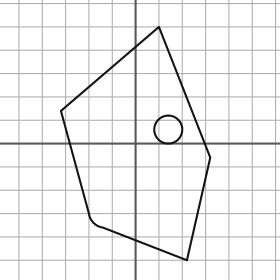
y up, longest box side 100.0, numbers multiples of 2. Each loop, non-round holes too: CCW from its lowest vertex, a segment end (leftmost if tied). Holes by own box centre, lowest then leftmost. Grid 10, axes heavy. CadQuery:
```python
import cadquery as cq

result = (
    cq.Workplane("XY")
    .moveTo(22.0, -50.0)
    .lineTo(32.0, -6.0)
    .lineTo(10.0, 50.0)
    .lineTo(-32.0, 14.0)
    .lineTo(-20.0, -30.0)
    .threePointArc((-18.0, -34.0), (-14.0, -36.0))
    .close()
    .moveTo(14.0, 6.0)
    .circle(6.0)
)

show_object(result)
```